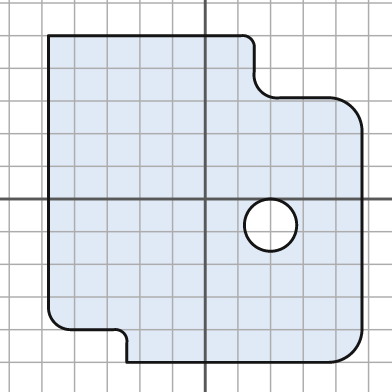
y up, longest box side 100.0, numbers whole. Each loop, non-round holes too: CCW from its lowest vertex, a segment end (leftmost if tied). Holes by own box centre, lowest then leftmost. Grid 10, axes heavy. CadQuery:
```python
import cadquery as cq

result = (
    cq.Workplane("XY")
    .moveTo(-24.0, -50.0)
    .lineTo(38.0, -50.0)
    .threePointArc((45.0, -47.0), (48.0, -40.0))
    .lineTo(48.0, 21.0)
    .threePointArc((45.0, 28.0), (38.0, 31.0))
    .lineTo(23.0, 31.0)
    .threePointArc((17.0, 33.0), (15.0, 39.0))
    .lineTo(15.0, 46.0)
    .threePointArc((14.0, 49.0), (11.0, 50.0))
    .lineTo(-48.0, 50.0)
    .lineTo(-48.0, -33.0)
    .threePointArc((-46.0, -38.0), (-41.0, -40.0))
    .lineTo(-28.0, -40.0)
    .threePointArc((-25.0, -41.0), (-24.0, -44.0))
    .close()
    .moveTo(20.0, -8.0)
    .circle(8.0)
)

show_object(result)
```